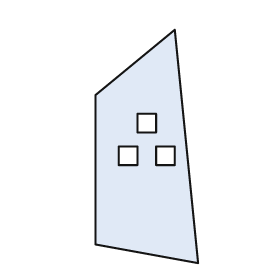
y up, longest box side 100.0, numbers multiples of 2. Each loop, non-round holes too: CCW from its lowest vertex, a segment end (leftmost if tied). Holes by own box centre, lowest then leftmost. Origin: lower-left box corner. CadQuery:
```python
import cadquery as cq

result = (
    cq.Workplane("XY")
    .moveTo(44.0, 0.0)
    .lineTo(34.0, 100.0)
    .lineTo(0.0, 72.0)
    .lineTo(0.0, 8.0)
    .close()
    .moveTo(10.0, 42.0)
    .lineTo(18.0, 42.0)
    .lineTo(18.0, 50.0)
    .lineTo(10.0, 50.0)
    .close()
    .moveTo(26.0, 42.0)
    .lineTo(34.0, 42.0)
    .lineTo(34.0, 50.0)
    .lineTo(26.0, 50.0)
    .close()
    .moveTo(18.0, 56.0)
    .lineTo(26.0, 56.0)
    .lineTo(26.0, 64.0)
    .lineTo(18.0, 64.0)
    .close()
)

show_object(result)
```